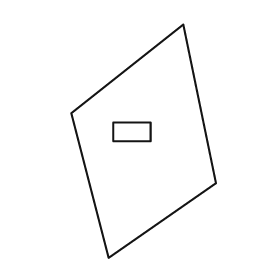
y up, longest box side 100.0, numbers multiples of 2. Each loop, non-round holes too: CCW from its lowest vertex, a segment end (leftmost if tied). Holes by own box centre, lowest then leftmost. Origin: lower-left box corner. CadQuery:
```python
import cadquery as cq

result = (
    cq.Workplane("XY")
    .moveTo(16.0, 0.0)
    .lineTo(62.0, 32.0)
    .lineTo(48.0, 100.0)
    .lineTo(0.0, 62.0)
    .close()
    .moveTo(18.0, 50.0)
    .lineTo(34.0, 50.0)
    .lineTo(34.0, 58.0)
    .lineTo(18.0, 58.0)
    .close()
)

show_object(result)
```